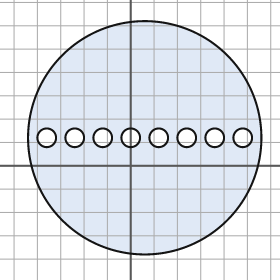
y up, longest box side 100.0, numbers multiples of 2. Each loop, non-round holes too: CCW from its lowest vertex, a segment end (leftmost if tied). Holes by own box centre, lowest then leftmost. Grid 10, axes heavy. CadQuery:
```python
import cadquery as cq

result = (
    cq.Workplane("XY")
    .moveTo(6.0, 12.0)
    .circle(50.0)
    .moveTo(-36.0, 12.0)
    .circle(4.0)
    .moveTo(-24.0, 12.0)
    .circle(4.0)
    .moveTo(-12.0, 12.0)
    .circle(4.0)
    .moveTo(0.0, 12.0)
    .circle(4.0)
    .moveTo(12.0, 12.0)
    .circle(4.0)
    .moveTo(24.0, 12.0)
    .circle(4.0)
    .moveTo(36.0, 12.0)
    .circle(4.0)
    .moveTo(48.0, 12.0)
    .circle(4.0)
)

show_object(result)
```